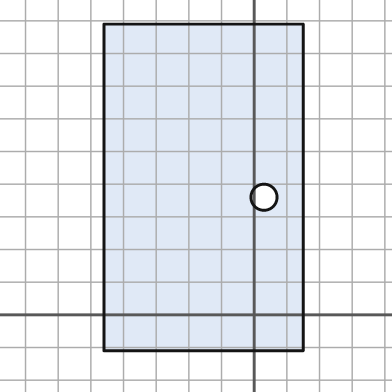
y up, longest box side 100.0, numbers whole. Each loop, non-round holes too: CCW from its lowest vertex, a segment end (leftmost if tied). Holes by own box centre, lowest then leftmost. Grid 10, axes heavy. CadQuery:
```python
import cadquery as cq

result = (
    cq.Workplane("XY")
    .moveTo(-46.0, -11.0)
    .lineTo(15.0, -11.0)
    .lineTo(15.0, 89.0)
    .lineTo(-46.0, 89.0)
    .close()
    .moveTo(3.0, 36.0)
    .circle(4.0)
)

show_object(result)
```